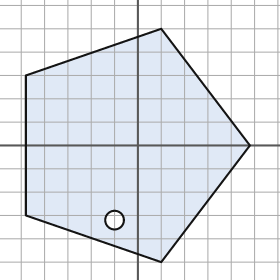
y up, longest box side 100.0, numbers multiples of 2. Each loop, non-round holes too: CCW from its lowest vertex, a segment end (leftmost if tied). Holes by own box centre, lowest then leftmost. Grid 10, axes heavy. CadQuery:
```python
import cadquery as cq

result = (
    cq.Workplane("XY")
    .moveTo(10.0, -50.0)
    .lineTo(48.0, 0.0)
    .lineTo(10.0, 50.0)
    .lineTo(-48.0, 30.0)
    .lineTo(-48.0, -30.0)
    .close()
    .moveTo(-10.0, -32.0)
    .circle(4.0)
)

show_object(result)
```